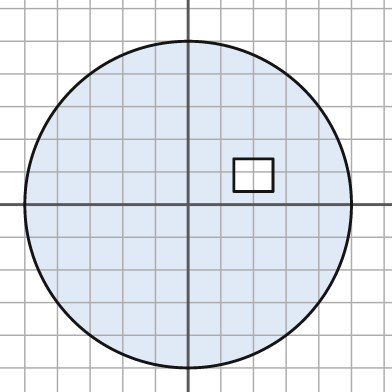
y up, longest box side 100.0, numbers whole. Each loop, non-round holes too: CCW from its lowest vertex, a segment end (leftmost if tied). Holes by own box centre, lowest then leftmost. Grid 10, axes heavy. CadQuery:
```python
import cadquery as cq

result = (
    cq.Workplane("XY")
    .moveTo(0.0, 0.0)
    .circle(50.0)
    .moveTo(14.0, 4.0)
    .lineTo(26.0, 4.0)
    .lineTo(26.0, 14.0)
    .lineTo(14.0, 14.0)
    .close()
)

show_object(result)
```